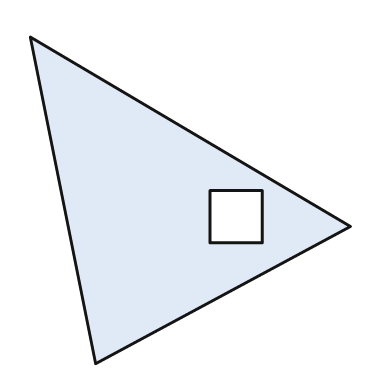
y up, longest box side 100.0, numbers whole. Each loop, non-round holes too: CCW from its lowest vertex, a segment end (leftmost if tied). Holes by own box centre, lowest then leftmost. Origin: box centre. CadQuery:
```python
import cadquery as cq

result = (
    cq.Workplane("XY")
    .moveTo(-29.0, -50.0)
    .lineTo(49.0, -8.0)
    .lineTo(-49.0, 50.0)
    .close()
    .moveTo(6.0, -13.0)
    .lineTo(22.0, -13.0)
    .lineTo(22.0, 3.0)
    .lineTo(6.0, 3.0)
    .close()
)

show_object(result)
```